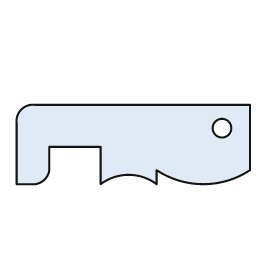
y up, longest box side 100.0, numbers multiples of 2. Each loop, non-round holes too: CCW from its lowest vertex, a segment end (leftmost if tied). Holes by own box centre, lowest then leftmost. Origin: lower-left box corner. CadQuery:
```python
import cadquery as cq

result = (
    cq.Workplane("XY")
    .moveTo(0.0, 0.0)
    .lineTo(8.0, 0.0)
    .threePointArc((12.0, 2.0), (14.0, 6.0))
    .lineTo(14.0, 16.0)
    .lineTo(36.0, 16.0)
    .lineTo(36.0, 0.0)
    .threePointArc((48.0, 4.0), (60.0, 0.0))
    .lineTo(60.0, 6.0)
    .threePointArc((80.0, 0.0), (100.0, 6.0))
    .lineTo(100.0, 34.0)
    .lineTo(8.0, 34.0)
    .threePointArc((2.0, 32.0), (0.0, 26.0))
    .close()
    .moveTo(88.0, 24.0)
    .circle(4.0)
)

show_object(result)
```